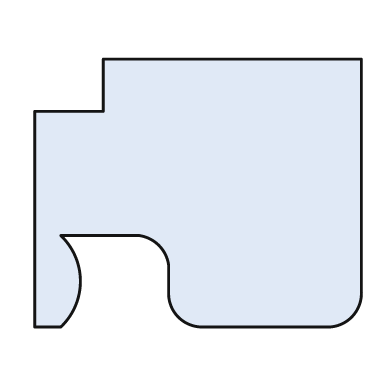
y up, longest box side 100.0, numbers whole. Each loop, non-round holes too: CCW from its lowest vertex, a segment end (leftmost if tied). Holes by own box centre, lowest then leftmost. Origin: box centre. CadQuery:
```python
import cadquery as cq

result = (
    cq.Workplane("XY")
    .moveTo(-50.0, -41.0)
    .lineTo(-42.0, -41.0)
    .threePointArc((-36.0, -27.0), (-42.0, -13.0))
    .lineTo(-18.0, -13.0)
    .threePointArc((-12.0, -16.0), (-9.0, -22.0))
    .lineTo(-9.0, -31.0)
    .threePointArc((-6.0, -38.0), (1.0, -41.0))
    .lineTo(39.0, -41.0)
    .threePointArc((47.0, -38.0), (50.0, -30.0))
    .lineTo(50.0, 41.0)
    .lineTo(-29.0, 41.0)
    .lineTo(-29.0, 25.0)
    .lineTo(-50.0, 25.0)
    .close()
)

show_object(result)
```